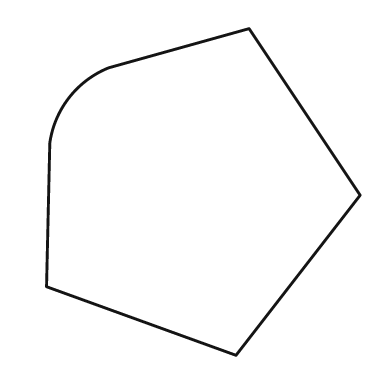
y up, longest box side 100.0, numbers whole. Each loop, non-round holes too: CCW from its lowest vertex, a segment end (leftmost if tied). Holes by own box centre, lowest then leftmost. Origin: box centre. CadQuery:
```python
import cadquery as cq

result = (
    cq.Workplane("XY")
    .moveTo(10.0, -50.0)
    .lineTo(48.0, -1.0)
    .lineTo(14.0, 50.0)
    .lineTo(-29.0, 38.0)
    .threePointArc((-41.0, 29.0), (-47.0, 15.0))
    .lineTo(-48.0, -29.0)
    .close()
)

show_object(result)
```